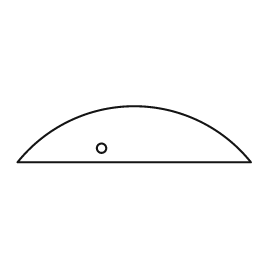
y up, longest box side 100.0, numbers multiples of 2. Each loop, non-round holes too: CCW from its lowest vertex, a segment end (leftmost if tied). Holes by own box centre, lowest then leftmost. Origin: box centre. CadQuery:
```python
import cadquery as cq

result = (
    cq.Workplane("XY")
    .moveTo(-50.0, -12.0)
    .lineTo(50.0, -12.0)
    .threePointArc((0.0, 12.0), (-50.0, -12.0))
    .close()
    .moveTo(-14.0, -6.0)
    .circle(2.0)
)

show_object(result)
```